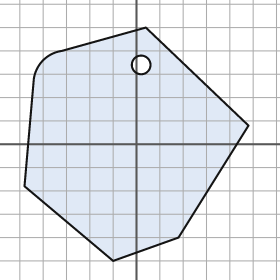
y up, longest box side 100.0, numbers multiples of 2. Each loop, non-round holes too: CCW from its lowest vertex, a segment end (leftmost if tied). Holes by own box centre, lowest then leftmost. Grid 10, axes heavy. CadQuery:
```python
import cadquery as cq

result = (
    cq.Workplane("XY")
    .moveTo(-10.0, -50.0)
    .lineTo(18.0, -40.0)
    .lineTo(48.0, 8.0)
    .lineTo(4.0, 50.0)
    .lineTo(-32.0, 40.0)
    .threePointArc((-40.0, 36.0), (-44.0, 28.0))
    .lineTo(-48.0, -18.0)
    .close()
    .moveTo(2.0, 34.0)
    .circle(4.0)
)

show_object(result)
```